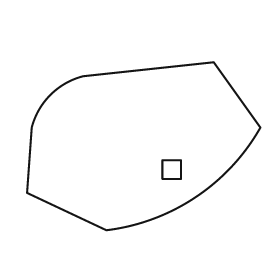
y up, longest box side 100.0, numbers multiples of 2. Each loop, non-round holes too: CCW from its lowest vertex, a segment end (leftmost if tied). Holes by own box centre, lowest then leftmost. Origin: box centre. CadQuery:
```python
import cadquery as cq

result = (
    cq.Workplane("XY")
    .moveTo(-16.0, -36.0)
    .threePointArc((22.0, -22.0), (50.0, 8.0))
    .lineTo(30.0, 36.0)
    .lineTo(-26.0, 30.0)
    .threePointArc((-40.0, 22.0), (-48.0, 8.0))
    .lineTo(-50.0, -20.0)
    .close()
    .moveTo(8.0, -14.0)
    .lineTo(16.0, -14.0)
    .lineTo(16.0, -6.0)
    .lineTo(8.0, -6.0)
    .close()
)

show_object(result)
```